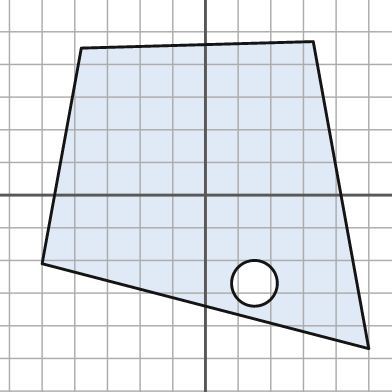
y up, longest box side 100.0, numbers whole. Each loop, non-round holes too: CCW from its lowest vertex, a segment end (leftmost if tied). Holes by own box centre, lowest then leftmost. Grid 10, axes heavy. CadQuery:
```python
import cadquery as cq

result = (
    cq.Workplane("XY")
    .moveTo(50.0, -47.0)
    .lineTo(33.0, 47.0)
    .lineTo(-38.0, 45.0)
    .lineTo(-50.0, -21.0)
    .close()
    .moveTo(15.0, -27.0)
    .circle(7.0)
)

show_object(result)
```